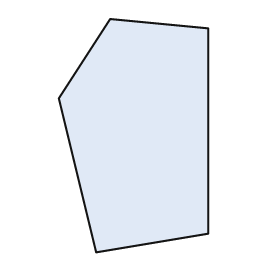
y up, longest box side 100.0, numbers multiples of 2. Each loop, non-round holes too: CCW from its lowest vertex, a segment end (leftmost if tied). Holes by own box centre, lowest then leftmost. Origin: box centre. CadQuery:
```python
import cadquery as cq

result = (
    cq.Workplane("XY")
    .moveTo(-16.0, -50.0)
    .lineTo(32.0, -42.0)
    .lineTo(32.0, 46.0)
    .lineTo(-10.0, 50.0)
    .lineTo(-32.0, 16.0)
    .close()
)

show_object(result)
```